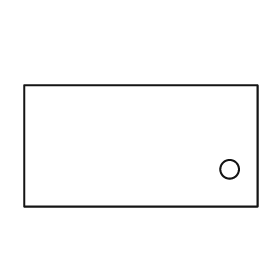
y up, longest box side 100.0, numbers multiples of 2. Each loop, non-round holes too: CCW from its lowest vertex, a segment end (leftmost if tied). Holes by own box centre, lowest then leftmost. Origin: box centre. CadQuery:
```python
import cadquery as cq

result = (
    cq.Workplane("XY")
    .moveTo(-50.0, -26.0)
    .lineTo(50.0, -26.0)
    .lineTo(50.0, 26.0)
    .lineTo(-50.0, 26.0)
    .close()
    .moveTo(38.0, -10.0)
    .circle(4.0)
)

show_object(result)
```